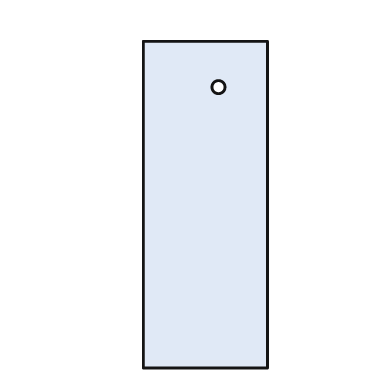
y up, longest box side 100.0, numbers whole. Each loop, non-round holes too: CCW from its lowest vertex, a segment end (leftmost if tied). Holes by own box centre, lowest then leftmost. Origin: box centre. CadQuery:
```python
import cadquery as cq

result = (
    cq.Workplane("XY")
    .moveTo(-19.0, -50.0)
    .lineTo(19.0, -50.0)
    .lineTo(19.0, 50.0)
    .lineTo(-19.0, 50.0)
    .close()
    .moveTo(4.0, 36.0)
    .circle(2.0)
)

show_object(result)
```